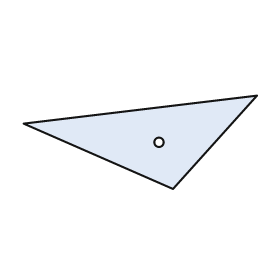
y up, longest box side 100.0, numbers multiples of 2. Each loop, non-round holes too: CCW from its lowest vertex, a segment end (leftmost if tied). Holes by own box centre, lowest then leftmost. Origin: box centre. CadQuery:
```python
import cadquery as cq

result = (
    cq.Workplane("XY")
    .moveTo(14.0, -20.0)
    .lineTo(50.0, 20.0)
    .lineTo(-50.0, 8.0)
    .close()
    .moveTo(8.0, 0.0)
    .circle(2.0)
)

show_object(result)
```